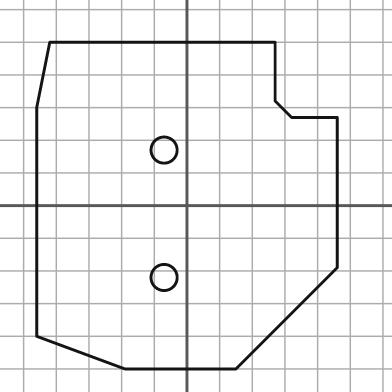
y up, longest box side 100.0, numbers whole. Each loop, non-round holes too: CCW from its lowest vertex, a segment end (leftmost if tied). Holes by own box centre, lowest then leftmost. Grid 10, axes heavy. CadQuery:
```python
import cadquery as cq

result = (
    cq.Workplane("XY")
    .moveTo(-19.0, -50.0)
    .lineTo(15.0, -50.0)
    .lineTo(46.0, -19.0)
    .lineTo(46.0, 27.0)
    .lineTo(32.0, 27.0)
    .lineTo(27.0, 32.0)
    .lineTo(27.0, 50.0)
    .lineTo(-42.0, 50.0)
    .lineTo(-46.0, 30.0)
    .lineTo(-46.0, -40.0)
    .close()
    .moveTo(-7.0, -22.0)
    .circle(4.0)
    .moveTo(-7.0, 17.0)
    .circle(4.0)
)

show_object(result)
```